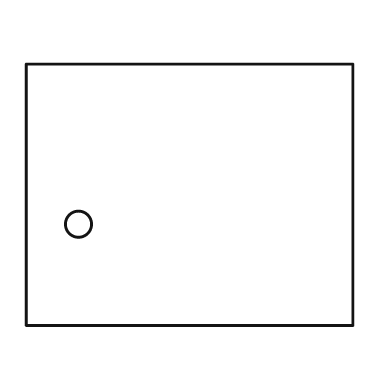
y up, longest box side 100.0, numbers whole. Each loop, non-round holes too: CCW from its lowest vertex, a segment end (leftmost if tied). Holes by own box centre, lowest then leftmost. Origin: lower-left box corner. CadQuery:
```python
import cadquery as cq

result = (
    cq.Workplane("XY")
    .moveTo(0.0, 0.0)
    .lineTo(100.0, 0.0)
    .lineTo(100.0, 80.0)
    .lineTo(0.0, 80.0)
    .close()
    .moveTo(16.0, 31.0)
    .circle(4.0)
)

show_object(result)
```